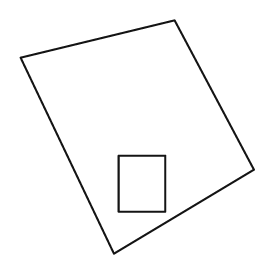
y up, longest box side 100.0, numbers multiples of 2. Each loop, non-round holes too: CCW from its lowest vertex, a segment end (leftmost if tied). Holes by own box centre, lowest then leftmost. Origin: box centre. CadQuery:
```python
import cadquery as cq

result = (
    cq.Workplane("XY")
    .moveTo(-10.0, -50.0)
    .lineTo(50.0, -14.0)
    .lineTo(16.0, 50.0)
    .lineTo(-50.0, 34.0)
    .close()
    .moveTo(-8.0, -32.0)
    .lineTo(12.0, -32.0)
    .lineTo(12.0, -8.0)
    .lineTo(-8.0, -8.0)
    .close()
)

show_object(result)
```